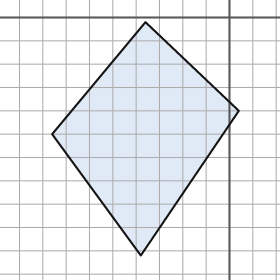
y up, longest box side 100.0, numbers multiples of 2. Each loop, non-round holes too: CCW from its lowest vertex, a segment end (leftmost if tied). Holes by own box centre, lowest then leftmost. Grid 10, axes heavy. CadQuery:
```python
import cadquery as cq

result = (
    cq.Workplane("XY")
    .moveTo(-38.0, -102.0)
    .lineTo(4.0, -40.0)
    .lineTo(-36.0, -2.0)
    .lineTo(-76.0, -50.0)
    .close()
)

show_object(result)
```